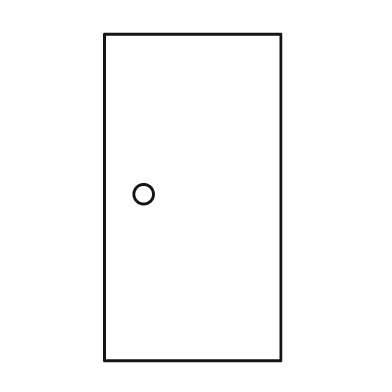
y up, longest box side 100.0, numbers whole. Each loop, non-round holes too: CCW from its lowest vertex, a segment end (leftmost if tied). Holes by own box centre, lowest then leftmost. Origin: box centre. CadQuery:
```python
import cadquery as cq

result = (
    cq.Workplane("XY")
    .moveTo(-27.0, -50.0)
    .lineTo(27.0, -50.0)
    .lineTo(27.0, 50.0)
    .lineTo(-27.0, 50.0)
    .close()
    .moveTo(-15.0, 1.0)
    .circle(3.0)
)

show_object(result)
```